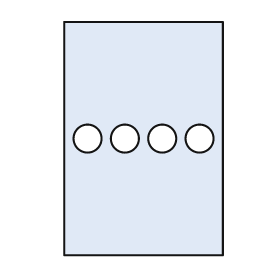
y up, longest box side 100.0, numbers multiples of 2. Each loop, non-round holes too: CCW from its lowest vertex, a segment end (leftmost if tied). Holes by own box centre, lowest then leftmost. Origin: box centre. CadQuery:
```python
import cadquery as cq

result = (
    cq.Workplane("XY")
    .moveTo(-34.0, -50.0)
    .lineTo(34.0, -50.0)
    .lineTo(34.0, 50.0)
    .lineTo(-34.0, 50.0)
    .close()
    .moveTo(-24.0, 0.0)
    .circle(6.0)
    .moveTo(-8.0, 0.0)
    .circle(6.0)
    .moveTo(8.0, 0.0)
    .circle(6.0)
    .moveTo(24.0, 0.0)
    .circle(6.0)
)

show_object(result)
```